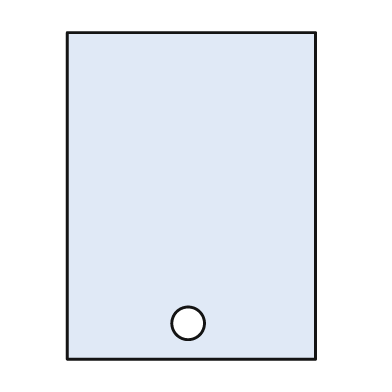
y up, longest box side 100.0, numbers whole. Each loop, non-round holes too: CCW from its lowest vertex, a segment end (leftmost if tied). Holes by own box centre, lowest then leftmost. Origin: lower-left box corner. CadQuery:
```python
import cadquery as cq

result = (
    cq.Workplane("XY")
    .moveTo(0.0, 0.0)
    .lineTo(76.0, 0.0)
    .lineTo(76.0, 100.0)
    .lineTo(0.0, 100.0)
    .close()
    .moveTo(37.0, 11.0)
    .circle(5.0)
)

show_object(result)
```